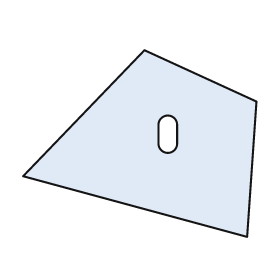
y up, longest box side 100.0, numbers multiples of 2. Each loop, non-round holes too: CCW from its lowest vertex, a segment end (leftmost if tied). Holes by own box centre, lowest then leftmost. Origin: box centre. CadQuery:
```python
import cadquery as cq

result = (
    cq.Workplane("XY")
    .moveTo(46.0, -40.0)
    .lineTo(50.0, 18.0)
    .lineTo(2.0, 40.0)
    .lineTo(-50.0, -14.0)
    .close()
    .moveTo(8.0, 0.0)
    .threePointArc((12.0, -4.0), (16.0, 0.0))
    .lineTo(16.0, 8.0)
    .threePointArc((12.0, 12.0), (8.0, 8.0))
    .close()
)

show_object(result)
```